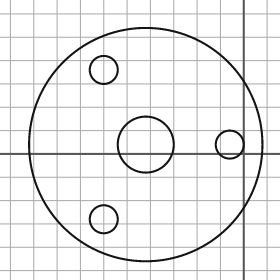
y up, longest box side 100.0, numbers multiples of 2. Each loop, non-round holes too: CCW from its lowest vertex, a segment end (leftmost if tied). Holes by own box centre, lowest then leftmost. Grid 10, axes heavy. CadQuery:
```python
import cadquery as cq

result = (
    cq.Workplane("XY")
    .moveTo(-42.0, 4.0)
    .circle(50.0)
    .moveTo(-60.0, -28.0)
    .circle(6.0)
    .moveTo(-42.0, 4.0)
    .circle(12.0)
    .moveTo(-6.0, 4.0)
    .circle(6.0)
    .moveTo(-60.0, 36.0)
    .circle(6.0)
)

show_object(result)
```